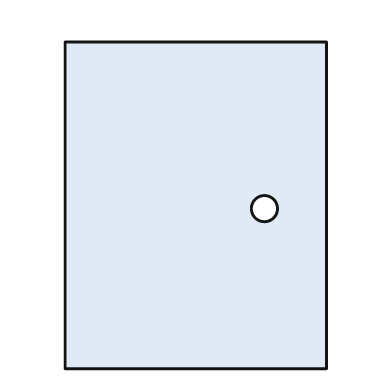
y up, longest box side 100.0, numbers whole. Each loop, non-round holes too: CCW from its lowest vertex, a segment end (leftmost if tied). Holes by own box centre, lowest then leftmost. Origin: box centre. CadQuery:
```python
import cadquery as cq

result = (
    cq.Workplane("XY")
    .moveTo(-40.0, -50.0)
    .lineTo(40.0, -50.0)
    .lineTo(40.0, 50.0)
    .lineTo(-40.0, 50.0)
    .close()
    .moveTo(21.0, -1.0)
    .circle(4.0)
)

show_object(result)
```